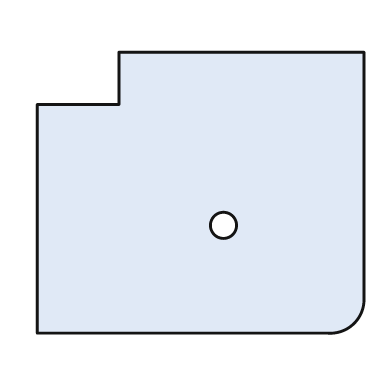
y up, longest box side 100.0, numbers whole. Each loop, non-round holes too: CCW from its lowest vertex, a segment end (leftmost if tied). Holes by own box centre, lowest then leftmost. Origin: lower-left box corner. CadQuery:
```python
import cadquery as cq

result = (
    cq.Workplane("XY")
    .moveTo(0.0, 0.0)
    .lineTo(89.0, 0.0)
    .threePointArc((97.0, 3.0), (100.0, 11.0))
    .lineTo(100.0, 86.0)
    .lineTo(25.0, 86.0)
    .lineTo(25.0, 70.0)
    .lineTo(0.0, 70.0)
    .close()
    .moveTo(57.0, 33.0)
    .circle(4.0)
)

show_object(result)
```